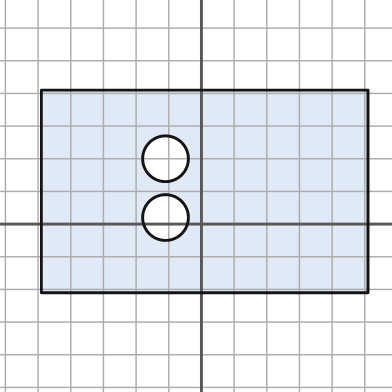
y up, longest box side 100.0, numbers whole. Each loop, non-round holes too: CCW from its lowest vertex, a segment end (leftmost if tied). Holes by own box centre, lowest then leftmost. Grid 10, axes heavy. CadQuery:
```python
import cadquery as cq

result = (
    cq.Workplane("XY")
    .moveTo(-49.0, -21.0)
    .lineTo(51.0, -21.0)
    .lineTo(51.0, 41.0)
    .lineTo(-49.0, 41.0)
    .close()
    .moveTo(-11.0, 2.0)
    .circle(7.0)
    .moveTo(-11.0, 20.0)
    .circle(7.0)
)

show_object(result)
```